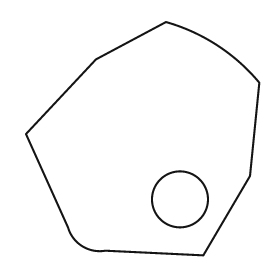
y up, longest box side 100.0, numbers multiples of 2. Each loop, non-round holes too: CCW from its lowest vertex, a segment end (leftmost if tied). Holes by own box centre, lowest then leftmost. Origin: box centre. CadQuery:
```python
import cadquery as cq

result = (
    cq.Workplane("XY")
    .moveTo(26.0, -50.0)
    .lineTo(46.0, -16.0)
    .lineTo(50.0, 24.0)
    .threePointArc((32.0, 40.0), (10.0, 50.0))
    .lineTo(-20.0, 34.0)
    .lineTo(-50.0, 2.0)
    .lineTo(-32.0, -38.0)
    .threePointArc((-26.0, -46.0), (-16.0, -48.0))
    .close()
    .moveTo(16.0, -26.0)
    .circle(12.0)
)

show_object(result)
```